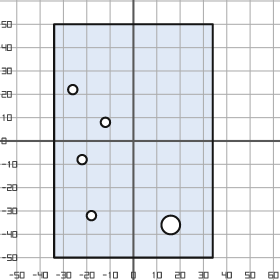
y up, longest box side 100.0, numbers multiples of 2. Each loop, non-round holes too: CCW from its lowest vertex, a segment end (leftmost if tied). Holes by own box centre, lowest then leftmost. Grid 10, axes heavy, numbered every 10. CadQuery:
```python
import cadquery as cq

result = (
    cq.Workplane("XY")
    .moveTo(-34.0, -50.0)
    .lineTo(34.0, -50.0)
    .lineTo(34.0, 50.0)
    .lineTo(-34.0, 50.0)
    .close()
    .moveTo(16.0, -36.0)
    .circle(4.0)
    .moveTo(-18.0, -32.0)
    .circle(2.0)
    .moveTo(-22.0, -8.0)
    .circle(2.0)
    .moveTo(-12.0, 8.0)
    .circle(2.0)
    .moveTo(-26.0, 22.0)
    .circle(2.0)
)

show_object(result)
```